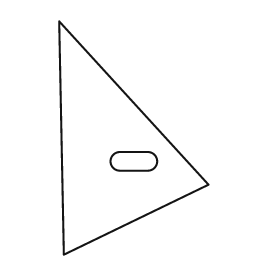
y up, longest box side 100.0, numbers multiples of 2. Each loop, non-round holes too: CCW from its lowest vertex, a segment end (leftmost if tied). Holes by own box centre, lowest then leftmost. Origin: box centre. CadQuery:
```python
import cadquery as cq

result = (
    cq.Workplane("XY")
    .moveTo(-30.0, -50.0)
    .lineTo(32.0, -20.0)
    .lineTo(-32.0, 50.0)
    .close()
    .moveTo(-6.0, -14.0)
    .lineTo(6.0, -14.0)
    .threePointArc((10.0, -10.0), (6.0, -6.0))
    .lineTo(-6.0, -6.0)
    .threePointArc((-10.0, -10.0), (-6.0, -14.0))
    .close()
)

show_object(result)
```